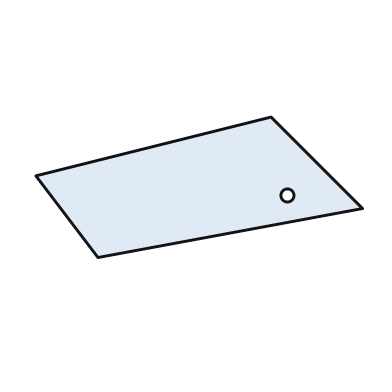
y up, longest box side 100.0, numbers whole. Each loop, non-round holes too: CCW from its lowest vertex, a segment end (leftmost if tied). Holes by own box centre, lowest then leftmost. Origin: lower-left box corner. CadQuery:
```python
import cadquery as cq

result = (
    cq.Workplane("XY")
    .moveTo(19.0, 0.0)
    .lineTo(100.0, 15.0)
    .lineTo(72.0, 43.0)
    .lineTo(0.0, 25.0)
    .close()
    .moveTo(77.0, 19.0)
    .circle(2.0)
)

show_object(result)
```